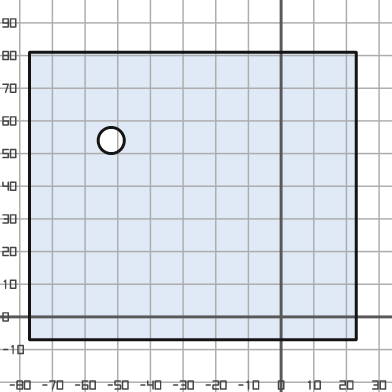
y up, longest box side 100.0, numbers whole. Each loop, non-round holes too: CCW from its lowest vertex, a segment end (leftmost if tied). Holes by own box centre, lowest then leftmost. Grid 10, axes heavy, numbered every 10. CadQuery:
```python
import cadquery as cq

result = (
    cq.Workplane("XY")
    .moveTo(-77.0, -7.0)
    .lineTo(23.0, -7.0)
    .lineTo(23.0, 81.0)
    .lineTo(-77.0, 81.0)
    .close()
    .moveTo(-52.0, 54.0)
    .circle(4.0)
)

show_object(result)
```